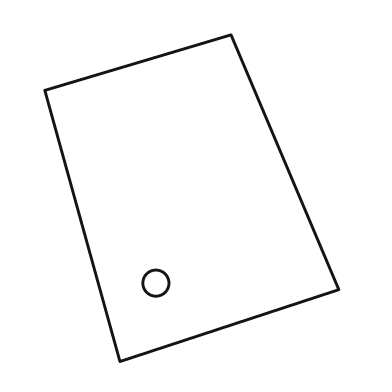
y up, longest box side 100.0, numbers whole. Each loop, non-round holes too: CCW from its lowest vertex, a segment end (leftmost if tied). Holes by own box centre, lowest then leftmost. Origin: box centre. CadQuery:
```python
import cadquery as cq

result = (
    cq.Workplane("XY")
    .moveTo(-22.0, -50.0)
    .lineTo(45.0, -28.0)
    .lineTo(12.0, 50.0)
    .lineTo(-45.0, 33.0)
    .close()
    .moveTo(-11.0, -26.0)
    .circle(4.0)
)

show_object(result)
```